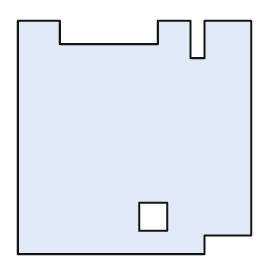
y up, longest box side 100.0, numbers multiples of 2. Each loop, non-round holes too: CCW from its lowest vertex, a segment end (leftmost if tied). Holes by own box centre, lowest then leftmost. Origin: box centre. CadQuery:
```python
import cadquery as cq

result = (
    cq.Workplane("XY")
    .moveTo(-50.0, -50.0)
    .lineTo(30.0, -50.0)
    .lineTo(30.0, -42.0)
    .lineTo(50.0, -42.0)
    .lineTo(50.0, 50.0)
    .lineTo(30.0, 50.0)
    .lineTo(30.0, 34.0)
    .lineTo(24.0, 34.0)
    .lineTo(24.0, 50.0)
    .lineTo(10.0, 50.0)
    .lineTo(10.0, 40.0)
    .lineTo(-32.0, 40.0)
    .lineTo(-32.0, 50.0)
    .lineTo(-50.0, 50.0)
    .close()
    .moveTo(2.0, -40.0)
    .lineTo(14.0, -40.0)
    .lineTo(14.0, -28.0)
    .lineTo(2.0, -28.0)
    .close()
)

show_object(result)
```